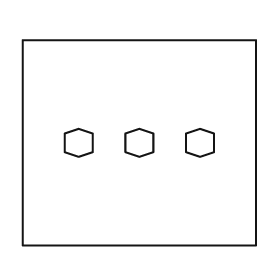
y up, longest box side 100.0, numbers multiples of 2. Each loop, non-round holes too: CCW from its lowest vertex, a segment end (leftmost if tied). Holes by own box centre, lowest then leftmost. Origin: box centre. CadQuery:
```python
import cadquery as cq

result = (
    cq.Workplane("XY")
    .moveTo(-50.0, -44.0)
    .lineTo(50.0, -44.0)
    .lineTo(50.0, 44.0)
    .lineTo(-50.0, 44.0)
    .close()
    .moveTo(-26.0, -6.0)
    .lineTo(-20.0, -4.0)
    .lineTo(-20.0, 4.0)
    .lineTo(-26.0, 6.0)
    .lineTo(-32.0, 4.0)
    .lineTo(-32.0, -4.0)
    .close()
    .moveTo(0.0, -6.0)
    .lineTo(6.0, -4.0)
    .lineTo(6.0, 4.0)
    .lineTo(0.0, 6.0)
    .lineTo(-6.0, 4.0)
    .lineTo(-6.0, -4.0)
    .close()
    .moveTo(26.0, -6.0)
    .lineTo(32.0, -4.0)
    .lineTo(32.0, 4.0)
    .lineTo(26.0, 6.0)
    .lineTo(20.0, 4.0)
    .lineTo(20.0, -4.0)
    .close()
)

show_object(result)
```